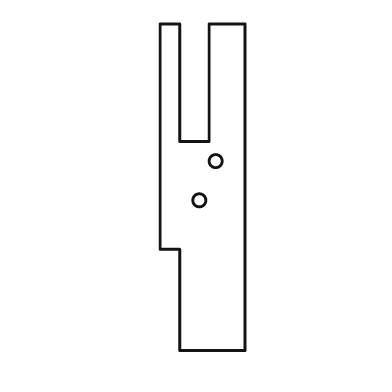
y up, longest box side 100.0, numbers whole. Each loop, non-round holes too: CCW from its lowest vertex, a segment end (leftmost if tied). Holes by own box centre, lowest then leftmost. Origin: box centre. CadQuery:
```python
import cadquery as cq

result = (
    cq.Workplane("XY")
    .moveTo(-7.0, -50.0)
    .lineTo(13.0, -50.0)
    .lineTo(13.0, 50.0)
    .lineTo(2.0, 50.0)
    .lineTo(2.0, 14.0)
    .lineTo(-7.0, 14.0)
    .lineTo(-7.0, 50.0)
    .lineTo(-13.0, 50.0)
    .lineTo(-13.0, -19.0)
    .lineTo(-7.0, -19.0)
    .close()
    .moveTo(-1.0, -4.0)
    .circle(2.0)
    .moveTo(4.0, 8.0)
    .circle(2.0)
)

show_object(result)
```